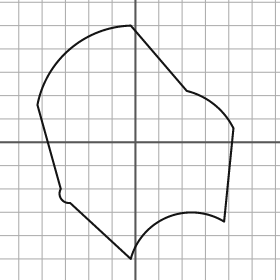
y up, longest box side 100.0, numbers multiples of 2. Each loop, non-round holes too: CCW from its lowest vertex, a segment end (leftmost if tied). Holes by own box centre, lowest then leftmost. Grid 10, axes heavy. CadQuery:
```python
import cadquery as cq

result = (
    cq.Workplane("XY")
    .moveTo(-2.0, -50.0)
    .threePointArc((14.0, -32.0), (38.0, -34.0))
    .lineTo(42.0, 6.0)
    .threePointArc((34.0, 16.0), (22.0, 22.0))
    .lineTo(-2.0, 50.0)
    .threePointArc((-28.0, 40.0), (-42.0, 16.0))
    .lineTo(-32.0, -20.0)
    .threePointArc((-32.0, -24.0), (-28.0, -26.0))
    .close()
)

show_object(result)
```